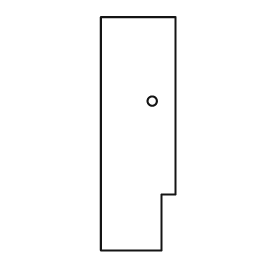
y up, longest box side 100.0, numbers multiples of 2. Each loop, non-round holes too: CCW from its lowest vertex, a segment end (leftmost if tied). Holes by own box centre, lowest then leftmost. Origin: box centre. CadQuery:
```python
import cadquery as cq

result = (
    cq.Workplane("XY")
    .moveTo(-16.0, -50.0)
    .lineTo(10.0, -50.0)
    .lineTo(10.0, -26.0)
    .lineTo(16.0, -26.0)
    .lineTo(16.0, 50.0)
    .lineTo(-16.0, 50.0)
    .close()
    .moveTo(6.0, 14.0)
    .circle(2.0)
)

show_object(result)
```